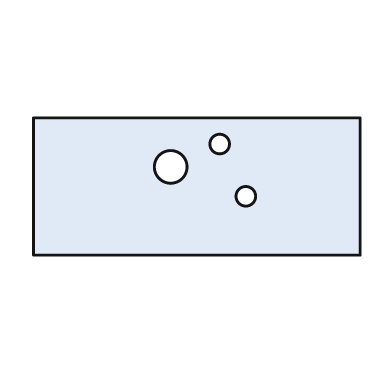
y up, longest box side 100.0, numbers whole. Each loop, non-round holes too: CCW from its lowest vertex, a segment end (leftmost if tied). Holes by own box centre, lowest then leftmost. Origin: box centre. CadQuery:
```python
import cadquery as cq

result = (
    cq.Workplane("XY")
    .moveTo(-50.0, -21.0)
    .lineTo(50.0, -21.0)
    .lineTo(50.0, 21.0)
    .lineTo(-50.0, 21.0)
    .close()
    .moveTo(15.0, -3.0)
    .circle(3.0)
    .moveTo(-8.0, 6.0)
    .circle(5.0)
    .moveTo(7.0, 13.0)
    .circle(3.0)
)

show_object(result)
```